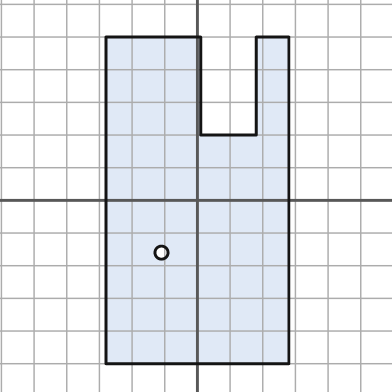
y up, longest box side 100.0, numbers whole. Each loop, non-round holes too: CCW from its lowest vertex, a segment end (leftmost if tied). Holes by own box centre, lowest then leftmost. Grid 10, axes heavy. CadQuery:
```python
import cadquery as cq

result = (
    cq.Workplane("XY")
    .moveTo(-28.0, -50.0)
    .lineTo(28.0, -50.0)
    .lineTo(28.0, 50.0)
    .lineTo(18.0, 50.0)
    .lineTo(18.0, 20.0)
    .lineTo(1.0, 20.0)
    .lineTo(1.0, 50.0)
    .lineTo(-28.0, 50.0)
    .close()
    .moveTo(-11.0, -16.0)
    .circle(2.0)
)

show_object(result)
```